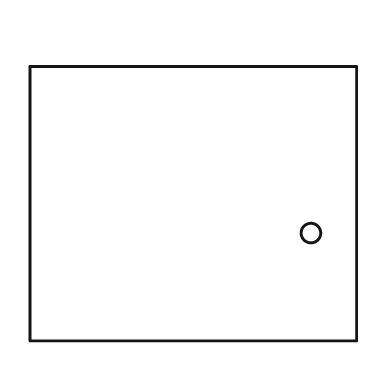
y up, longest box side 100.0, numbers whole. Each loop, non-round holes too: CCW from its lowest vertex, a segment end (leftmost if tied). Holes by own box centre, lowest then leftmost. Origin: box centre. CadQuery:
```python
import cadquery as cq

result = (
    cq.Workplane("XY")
    .moveTo(-50.0, -42.0)
    .lineTo(50.0, -42.0)
    .lineTo(50.0, 42.0)
    .lineTo(-50.0, 42.0)
    .close()
    .moveTo(36.0, -9.0)
    .circle(3.0)
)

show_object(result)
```